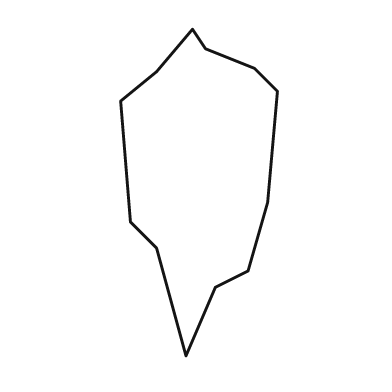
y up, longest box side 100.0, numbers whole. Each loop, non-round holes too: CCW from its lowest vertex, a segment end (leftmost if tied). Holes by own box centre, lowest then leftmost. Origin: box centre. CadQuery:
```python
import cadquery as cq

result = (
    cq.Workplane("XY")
    .moveTo(-4.0, -50.0)
    .lineTo(5.0, -29.0)
    .lineTo(15.0, -24.0)
    .lineTo(21.0, -3.0)
    .lineTo(24.0, 31.0)
    .lineTo(17.0, 38.0)
    .lineTo(2.0, 44.0)
    .lineTo(-2.0, 50.0)
    .lineTo(-13.0, 37.0)
    .lineTo(-24.0, 28.0)
    .lineTo(-21.0, -9.0)
    .lineTo(-13.0, -17.0)
    .close()
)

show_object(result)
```